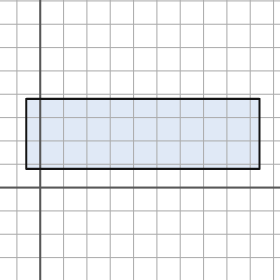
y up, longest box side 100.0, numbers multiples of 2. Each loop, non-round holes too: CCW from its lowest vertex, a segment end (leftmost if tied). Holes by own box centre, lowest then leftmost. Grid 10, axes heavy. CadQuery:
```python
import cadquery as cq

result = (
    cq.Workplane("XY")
    .moveTo(-6.0, 8.0)
    .lineTo(94.0, 8.0)
    .lineTo(94.0, 38.0)
    .lineTo(-6.0, 38.0)
    .close()
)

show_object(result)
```